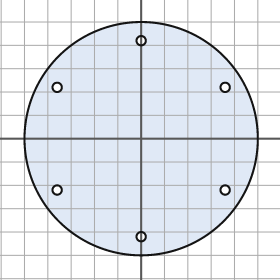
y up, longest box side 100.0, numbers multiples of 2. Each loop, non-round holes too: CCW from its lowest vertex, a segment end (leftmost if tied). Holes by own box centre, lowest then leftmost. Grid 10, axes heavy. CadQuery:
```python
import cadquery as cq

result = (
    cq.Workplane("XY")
    .moveTo(0.0, 0.0)
    .circle(50.0)
    .moveTo(0.0, -42.0)
    .circle(2.0)
    .moveTo(-36.0, -22.0)
    .circle(2.0)
    .moveTo(36.0, -22.0)
    .circle(2.0)
    .moveTo(-36.0, 22.0)
    .circle(2.0)
    .moveTo(36.0, 22.0)
    .circle(2.0)
    .moveTo(0.0, 42.0)
    .circle(2.0)
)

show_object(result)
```